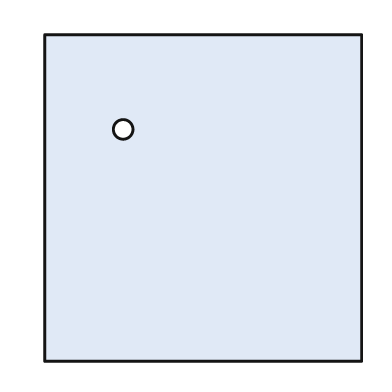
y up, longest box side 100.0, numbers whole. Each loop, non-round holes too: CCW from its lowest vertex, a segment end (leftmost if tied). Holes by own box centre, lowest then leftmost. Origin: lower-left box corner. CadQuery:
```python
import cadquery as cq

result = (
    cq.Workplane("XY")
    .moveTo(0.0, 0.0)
    .lineTo(97.0, 0.0)
    .lineTo(97.0, 100.0)
    .lineTo(0.0, 100.0)
    .close()
    .moveTo(24.0, 71.0)
    .circle(3.0)
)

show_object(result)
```